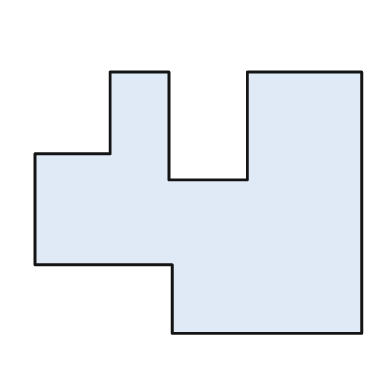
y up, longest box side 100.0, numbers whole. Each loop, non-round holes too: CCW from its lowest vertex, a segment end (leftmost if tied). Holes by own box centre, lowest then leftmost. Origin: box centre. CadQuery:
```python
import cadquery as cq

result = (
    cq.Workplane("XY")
    .moveTo(-8.0, -40.0)
    .lineTo(50.0, -40.0)
    .lineTo(50.0, 40.0)
    .lineTo(15.0, 40.0)
    .lineTo(15.0, 7.0)
    .lineTo(-9.0, 7.0)
    .lineTo(-9.0, 40.0)
    .lineTo(-27.0, 40.0)
    .lineTo(-27.0, 15.0)
    .lineTo(-50.0, 15.0)
    .lineTo(-50.0, -19.0)
    .lineTo(-8.0, -19.0)
    .close()
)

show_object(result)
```